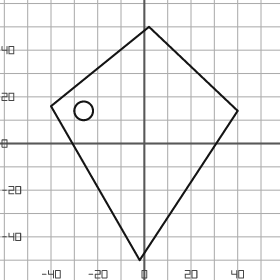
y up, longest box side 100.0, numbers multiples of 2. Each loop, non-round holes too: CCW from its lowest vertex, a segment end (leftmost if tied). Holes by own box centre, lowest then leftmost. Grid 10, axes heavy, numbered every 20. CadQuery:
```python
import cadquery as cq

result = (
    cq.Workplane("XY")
    .moveTo(-2.0, -50.0)
    .lineTo(40.0, 14.0)
    .lineTo(2.0, 50.0)
    .lineTo(-40.0, 16.0)
    .close()
    .moveTo(-26.0, 14.0)
    .circle(4.0)
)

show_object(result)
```